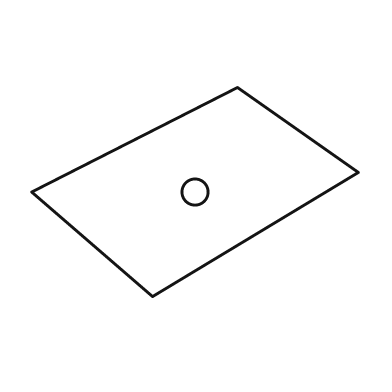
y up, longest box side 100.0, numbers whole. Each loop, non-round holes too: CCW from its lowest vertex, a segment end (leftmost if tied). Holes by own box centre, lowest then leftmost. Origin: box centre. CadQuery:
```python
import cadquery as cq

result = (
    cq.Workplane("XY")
    .moveTo(-13.0, -32.0)
    .lineTo(50.0, 6.0)
    .lineTo(13.0, 32.0)
    .lineTo(-50.0, 0.0)
    .close()
    .moveTo(0.0, 0.0)
    .circle(4.0)
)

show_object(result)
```